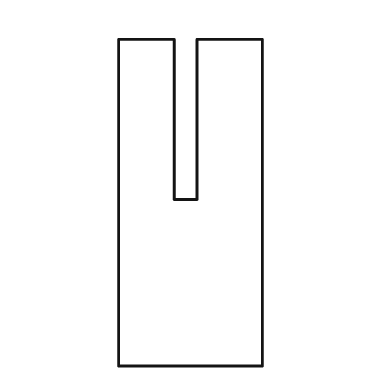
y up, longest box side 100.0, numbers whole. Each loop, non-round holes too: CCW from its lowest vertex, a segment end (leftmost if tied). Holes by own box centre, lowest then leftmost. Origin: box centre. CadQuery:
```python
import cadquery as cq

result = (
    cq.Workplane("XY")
    .moveTo(-22.0, -50.0)
    .lineTo(22.0, -50.0)
    .lineTo(22.0, 50.0)
    .lineTo(2.0, 50.0)
    .lineTo(2.0, 1.0)
    .lineTo(-5.0, 1.0)
    .lineTo(-5.0, 50.0)
    .lineTo(-22.0, 50.0)
    .close()
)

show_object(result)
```